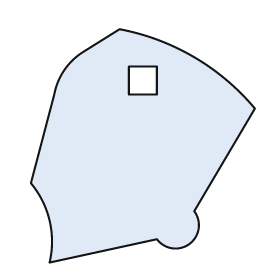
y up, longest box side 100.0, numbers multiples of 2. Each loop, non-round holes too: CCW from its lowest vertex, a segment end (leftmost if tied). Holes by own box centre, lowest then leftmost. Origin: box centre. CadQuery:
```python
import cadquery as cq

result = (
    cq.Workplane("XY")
    .moveTo(-40.0, -50.0)
    .lineTo(6.0, -40.0)
    .threePointArc((20.0, -42.0), (22.0, -28.0))
    .lineTo(48.0, 16.0)
    .threePointArc((22.0, 38.0), (-10.0, 50.0))
    .lineTo(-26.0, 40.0)
    .threePointArc((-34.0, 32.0), (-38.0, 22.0))
    .lineTo(-48.0, -16.0)
    .threePointArc((-40.0, -32.0), (-40.0, -50.0))
    .close()
    .moveTo(-6.0, 22.0)
    .lineTo(6.0, 22.0)
    .lineTo(6.0, 34.0)
    .lineTo(-6.0, 34.0)
    .close()
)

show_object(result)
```